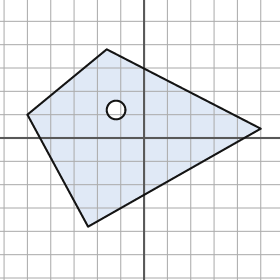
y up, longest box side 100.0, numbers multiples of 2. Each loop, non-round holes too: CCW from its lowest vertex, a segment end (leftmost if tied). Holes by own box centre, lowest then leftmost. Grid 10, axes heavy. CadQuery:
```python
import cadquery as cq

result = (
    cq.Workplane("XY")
    .moveTo(-24.0, -38.0)
    .lineTo(50.0, 4.0)
    .lineTo(-16.0, 38.0)
    .lineTo(-50.0, 10.0)
    .close()
    .moveTo(-12.0, 12.0)
    .circle(4.0)
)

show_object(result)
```